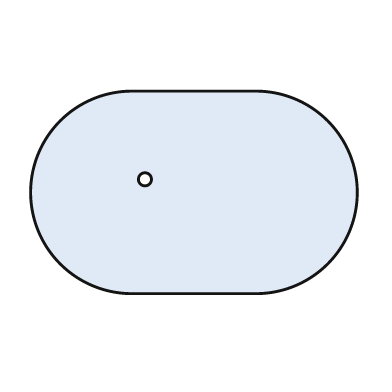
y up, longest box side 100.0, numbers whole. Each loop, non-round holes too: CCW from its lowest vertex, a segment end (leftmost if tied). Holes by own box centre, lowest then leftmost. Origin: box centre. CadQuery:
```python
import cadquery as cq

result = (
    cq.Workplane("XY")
    .moveTo(-19.0, -31.0)
    .lineTo(19.0, -31.0)
    .threePointArc((50.0, 0.0), (19.0, 31.0))
    .lineTo(-19.0, 31.0)
    .threePointArc((-50.0, 0.0), (-19.0, -31.0))
    .close()
    .moveTo(-15.0, 4.0)
    .circle(2.0)
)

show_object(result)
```